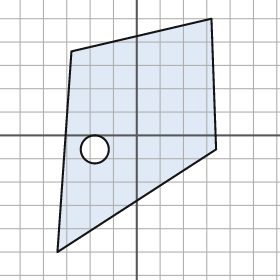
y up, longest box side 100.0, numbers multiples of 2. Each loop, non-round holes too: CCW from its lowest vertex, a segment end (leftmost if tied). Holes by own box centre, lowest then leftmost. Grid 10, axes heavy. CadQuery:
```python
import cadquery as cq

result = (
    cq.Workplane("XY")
    .moveTo(-34.0, -50.0)
    .lineTo(34.0, -6.0)
    .lineTo(32.0, 50.0)
    .lineTo(-28.0, 36.0)
    .close()
    .moveTo(-18.0, -6.0)
    .circle(6.0)
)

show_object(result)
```